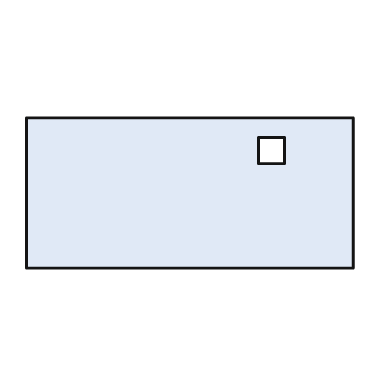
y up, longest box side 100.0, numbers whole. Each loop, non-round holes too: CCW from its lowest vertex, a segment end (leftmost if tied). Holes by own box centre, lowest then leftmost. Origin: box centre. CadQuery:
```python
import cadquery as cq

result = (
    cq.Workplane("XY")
    .moveTo(-50.0, -23.0)
    .lineTo(50.0, -23.0)
    .lineTo(50.0, 23.0)
    .lineTo(-50.0, 23.0)
    .close()
    .moveTo(21.0, 9.0)
    .lineTo(29.0, 9.0)
    .lineTo(29.0, 17.0)
    .lineTo(21.0, 17.0)
    .close()
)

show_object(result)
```